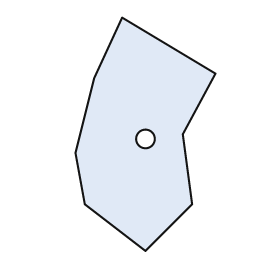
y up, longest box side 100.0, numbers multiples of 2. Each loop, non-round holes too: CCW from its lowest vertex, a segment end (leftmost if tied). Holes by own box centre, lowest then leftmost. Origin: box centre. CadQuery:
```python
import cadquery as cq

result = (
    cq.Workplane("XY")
    .moveTo(0.0, -50.0)
    .lineTo(20.0, -30.0)
    .lineTo(16.0, 0.0)
    .lineTo(30.0, 26.0)
    .lineTo(-10.0, 50.0)
    .lineTo(-22.0, 24.0)
    .lineTo(-30.0, -8.0)
    .lineTo(-26.0, -30.0)
    .close()
    .moveTo(0.0, -2.0)
    .circle(4.0)
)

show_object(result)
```